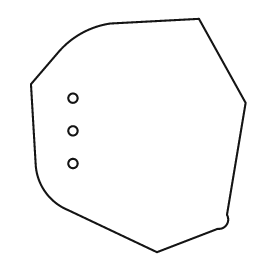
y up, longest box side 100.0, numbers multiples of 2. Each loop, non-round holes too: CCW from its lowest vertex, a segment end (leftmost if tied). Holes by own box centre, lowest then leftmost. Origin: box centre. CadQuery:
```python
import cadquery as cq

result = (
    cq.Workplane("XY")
    .moveTo(8.0, -50.0)
    .lineTo(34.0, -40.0)
    .threePointArc((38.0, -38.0), (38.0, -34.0))
    .lineTo(46.0, 14.0)
    .lineTo(26.0, 50.0)
    .lineTo(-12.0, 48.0)
    .threePointArc((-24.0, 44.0), (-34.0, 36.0))
    .lineTo(-46.0, 22.0)
    .lineTo(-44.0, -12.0)
    .threePointArc((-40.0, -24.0), (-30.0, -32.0))
    .close()
    .moveTo(-28.0, -12.0)
    .circle(2.0)
    .moveTo(-28.0, 2.0)
    .circle(2.0)
    .moveTo(-28.0, 16.0)
    .circle(2.0)
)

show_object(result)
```